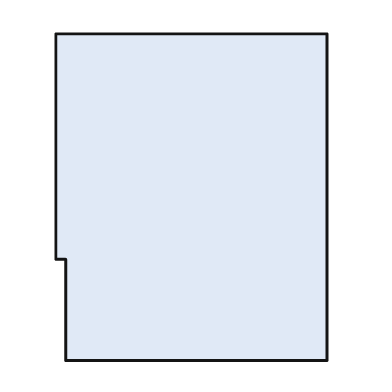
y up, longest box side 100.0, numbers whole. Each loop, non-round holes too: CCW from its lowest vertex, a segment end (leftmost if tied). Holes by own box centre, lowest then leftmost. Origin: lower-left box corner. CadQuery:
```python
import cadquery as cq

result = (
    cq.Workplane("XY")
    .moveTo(3.0, 0.0)
    .lineTo(83.0, 0.0)
    .lineTo(83.0, 100.0)
    .lineTo(0.0, 100.0)
    .lineTo(0.0, 31.0)
    .lineTo(3.0, 31.0)
    .close()
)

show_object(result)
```